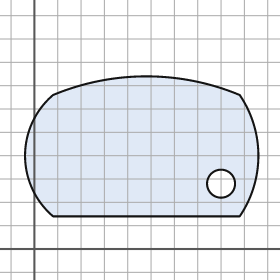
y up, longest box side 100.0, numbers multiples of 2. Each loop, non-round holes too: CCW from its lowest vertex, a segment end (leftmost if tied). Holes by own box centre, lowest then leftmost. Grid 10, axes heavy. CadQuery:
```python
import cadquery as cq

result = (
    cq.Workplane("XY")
    .moveTo(8.0, 14.0)
    .lineTo(88.0, 14.0)
    .threePointArc((96.0, 40.0), (88.0, 66.0))
    .threePointArc((48.0, 74.0), (8.0, 66.0))
    .threePointArc((-4.0, 40.0), (8.0, 14.0))
    .close()
    .moveTo(80.0, 28.0)
    .circle(6.0)
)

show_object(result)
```